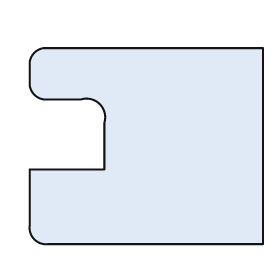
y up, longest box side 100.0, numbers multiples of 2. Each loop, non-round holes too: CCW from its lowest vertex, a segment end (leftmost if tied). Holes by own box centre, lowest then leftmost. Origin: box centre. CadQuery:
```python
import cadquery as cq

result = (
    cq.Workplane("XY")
    .moveTo(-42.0, -42.0)
    .lineTo(50.0, -42.0)
    .lineTo(50.0, 42.0)
    .lineTo(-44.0, 42.0)
    .threePointArc((-48.0, 40.0), (-50.0, 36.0))
    .lineTo(-50.0, 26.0)
    .threePointArc((-48.0, 22.0), (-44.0, 20.0))
    .lineTo(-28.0, 20.0)
    .threePointArc((-20.0, 18.0), (-18.0, 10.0))
    .lineTo(-18.0, -10.0)
    .lineTo(-50.0, -10.0)
    .lineTo(-50.0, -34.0)
    .threePointArc((-48.0, -40.0), (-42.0, -42.0))
    .close()
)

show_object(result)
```